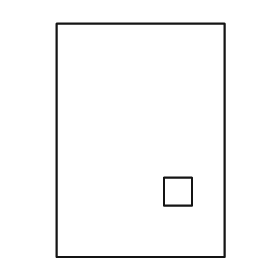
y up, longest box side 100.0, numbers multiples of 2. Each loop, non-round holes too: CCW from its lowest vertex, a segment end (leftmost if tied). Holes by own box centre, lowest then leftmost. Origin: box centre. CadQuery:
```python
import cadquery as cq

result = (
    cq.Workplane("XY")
    .moveTo(-36.0, -50.0)
    .lineTo(36.0, -50.0)
    .lineTo(36.0, 50.0)
    .lineTo(-36.0, 50.0)
    .close()
    .moveTo(10.0, -28.0)
    .lineTo(22.0, -28.0)
    .lineTo(22.0, -16.0)
    .lineTo(10.0, -16.0)
    .close()
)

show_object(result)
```